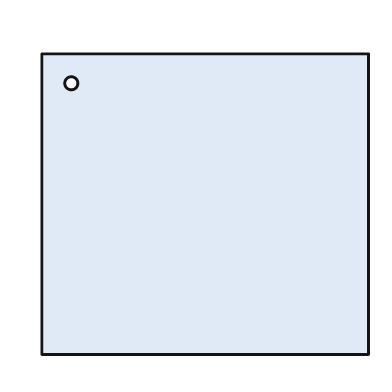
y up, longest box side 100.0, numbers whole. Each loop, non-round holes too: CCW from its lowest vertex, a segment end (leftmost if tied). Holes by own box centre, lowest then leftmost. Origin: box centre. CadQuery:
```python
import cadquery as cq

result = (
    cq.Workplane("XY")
    .moveTo(-50.0, -46.0)
    .lineTo(50.0, -46.0)
    .lineTo(50.0, 46.0)
    .lineTo(-50.0, 46.0)
    .close()
    .moveTo(-41.0, 37.0)
    .circle(2.0)
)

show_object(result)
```